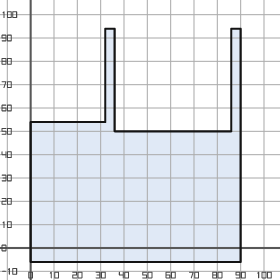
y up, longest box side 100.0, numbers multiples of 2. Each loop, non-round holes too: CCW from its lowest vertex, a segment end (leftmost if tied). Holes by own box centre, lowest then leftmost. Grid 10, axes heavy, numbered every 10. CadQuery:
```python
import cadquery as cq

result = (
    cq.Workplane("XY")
    .moveTo(0.0, -6.0)
    .lineTo(90.0, -6.0)
    .lineTo(90.0, 94.0)
    .lineTo(86.0, 94.0)
    .lineTo(86.0, 50.0)
    .lineTo(36.0, 50.0)
    .lineTo(36.0, 94.0)
    .lineTo(32.0, 94.0)
    .lineTo(32.0, 54.0)
    .lineTo(0.0, 54.0)
    .close()
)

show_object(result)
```